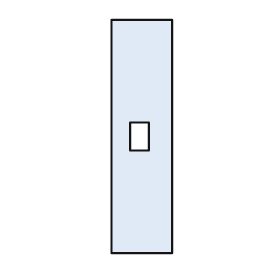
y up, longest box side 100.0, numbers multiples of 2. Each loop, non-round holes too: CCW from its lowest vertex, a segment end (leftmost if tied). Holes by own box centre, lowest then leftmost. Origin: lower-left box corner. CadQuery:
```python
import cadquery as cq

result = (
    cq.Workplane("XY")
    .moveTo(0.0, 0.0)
    .lineTo(26.0, 0.0)
    .lineTo(26.0, 100.0)
    .lineTo(0.0, 100.0)
    .close()
    .moveTo(8.0, 44.0)
    .lineTo(16.0, 44.0)
    .lineTo(16.0, 56.0)
    .lineTo(8.0, 56.0)
    .close()
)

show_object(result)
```